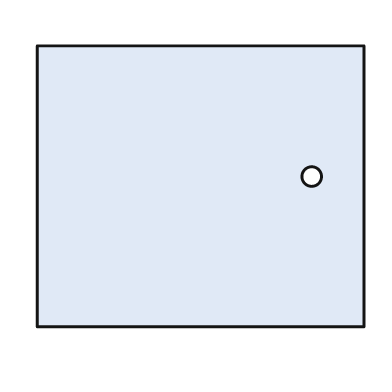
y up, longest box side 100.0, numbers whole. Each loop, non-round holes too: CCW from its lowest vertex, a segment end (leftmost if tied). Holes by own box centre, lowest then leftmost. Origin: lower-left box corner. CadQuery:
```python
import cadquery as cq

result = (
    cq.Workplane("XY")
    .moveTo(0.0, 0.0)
    .lineTo(100.0, 0.0)
    .lineTo(100.0, 86.0)
    .lineTo(0.0, 86.0)
    .close()
    .moveTo(84.0, 46.0)
    .circle(3.0)
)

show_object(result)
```